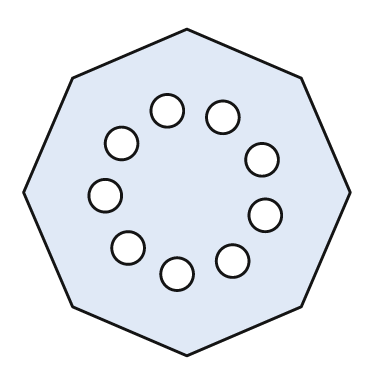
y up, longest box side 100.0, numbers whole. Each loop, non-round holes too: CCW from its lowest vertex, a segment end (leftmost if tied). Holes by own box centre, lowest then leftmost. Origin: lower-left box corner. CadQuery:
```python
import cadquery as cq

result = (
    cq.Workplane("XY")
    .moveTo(50.0, 0.0)
    .lineTo(85.0, 15.0)
    .lineTo(100.0, 50.0)
    .lineTo(85.0, 85.0)
    .lineTo(50.0, 100.0)
    .lineTo(15.0, 85.0)
    .lineTo(0.0, 50.0)
    .lineTo(15.0, 15.0)
    .close()
    .moveTo(47.0, 25.0)
    .circle(5.0)
    .moveTo(64.0, 29.0)
    .circle(5.0)
    .moveTo(32.0, 33.0)
    .circle(5.0)
    .moveTo(74.0, 43.0)
    .circle(5.0)
    .moveTo(25.0, 49.0)
    .circle(5.0)
    .moveTo(73.0, 60.0)
    .circle(5.0)
    .moveTo(30.0, 65.0)
    .circle(5.0)
    .moveTo(61.0, 73.0)
    .circle(5.0)
    .moveTo(44.0, 75.0)
    .circle(5.0)
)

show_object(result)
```